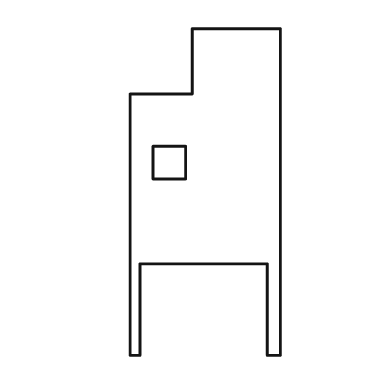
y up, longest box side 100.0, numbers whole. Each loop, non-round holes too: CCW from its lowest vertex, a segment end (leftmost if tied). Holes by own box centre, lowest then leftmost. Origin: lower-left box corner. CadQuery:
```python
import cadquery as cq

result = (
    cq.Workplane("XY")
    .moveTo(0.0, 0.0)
    .lineTo(3.0, 0.0)
    .lineTo(3.0, 28.0)
    .lineTo(42.0, 28.0)
    .lineTo(42.0, 0.0)
    .lineTo(46.0, 0.0)
    .lineTo(46.0, 100.0)
    .lineTo(19.0, 100.0)
    .lineTo(19.0, 80.0)
    .lineTo(0.0, 80.0)
    .close()
    .moveTo(7.0, 54.0)
    .lineTo(17.0, 54.0)
    .lineTo(17.0, 64.0)
    .lineTo(7.0, 64.0)
    .close()
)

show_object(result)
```